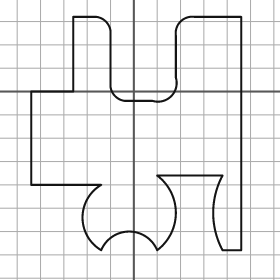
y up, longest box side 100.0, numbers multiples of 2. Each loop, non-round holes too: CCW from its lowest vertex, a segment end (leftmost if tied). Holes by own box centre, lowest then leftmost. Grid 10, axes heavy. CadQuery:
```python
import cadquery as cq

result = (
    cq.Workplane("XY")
    .moveTo(-14.0, -68.0)
    .threePointArc((-2.0, -60.0), (10.0, -68.0))
    .threePointArc((18.0, -52.0), (10.0, -36.0))
    .lineTo(38.0, -36.0)
    .threePointArc((34.0, -52.0), (38.0, -68.0))
    .lineTo(46.0, -68.0)
    .lineTo(46.0, 32.0)
    .lineTo(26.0, 32.0)
    .threePointArc((20.0, 30.0), (18.0, 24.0))
    .lineTo(18.0, 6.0)
    .threePointArc((16.0, -2.0), (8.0, -4.0))
    .lineTo(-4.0, -4.0)
    .threePointArc((-8.0, -2.0), (-10.0, 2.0))
    .lineTo(-10.0, 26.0)
    .threePointArc((-12.0, 30.0), (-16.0, 32.0))
    .lineTo(-26.0, 32.0)
    .lineTo(-26.0, 0.0)
    .lineTo(-44.0, 0.0)
    .lineTo(-44.0, -40.0)
    .lineTo(-14.0, -40.0)
    .threePointArc((-22.0, -54.0), (-14.0, -68.0))
    .close()
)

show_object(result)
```